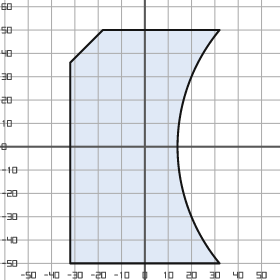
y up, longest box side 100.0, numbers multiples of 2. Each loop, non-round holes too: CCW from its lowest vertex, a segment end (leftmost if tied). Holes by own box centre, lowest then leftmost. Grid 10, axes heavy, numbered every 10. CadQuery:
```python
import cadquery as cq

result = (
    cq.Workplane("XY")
    .moveTo(-32.0, -50.0)
    .lineTo(32.0, -50.0)
    .threePointArc((14.0, 0.0), (32.0, 50.0))
    .lineTo(-18.0, 50.0)
    .lineTo(-32.0, 36.0)
    .close()
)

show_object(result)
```